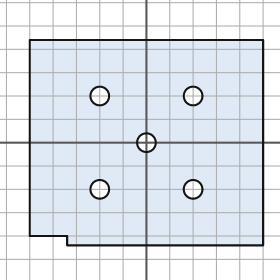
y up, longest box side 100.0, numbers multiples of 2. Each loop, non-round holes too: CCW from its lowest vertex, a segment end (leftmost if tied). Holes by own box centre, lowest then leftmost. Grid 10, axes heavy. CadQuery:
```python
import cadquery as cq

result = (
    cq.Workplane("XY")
    .moveTo(-34.0, -44.0)
    .lineTo(50.0, -44.0)
    .lineTo(50.0, 44.0)
    .lineTo(-50.0, 44.0)
    .lineTo(-50.0, -40.0)
    .lineTo(-34.0, -40.0)
    .close()
    .moveTo(-20.0, -20.0)
    .circle(4.0)
    .moveTo(20.0, -20.0)
    .circle(4.0)
    .moveTo(0.0, 0.0)
    .circle(4.0)
    .moveTo(-20.0, 20.0)
    .circle(4.0)
    .moveTo(20.0, 20.0)
    .circle(4.0)
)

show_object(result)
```